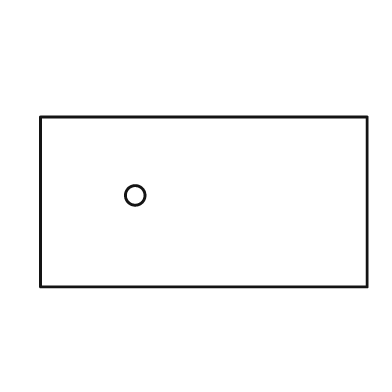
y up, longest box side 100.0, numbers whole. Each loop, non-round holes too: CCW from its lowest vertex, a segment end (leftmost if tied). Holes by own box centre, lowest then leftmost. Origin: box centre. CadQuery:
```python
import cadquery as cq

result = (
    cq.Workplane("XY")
    .moveTo(-50.0, -26.0)
    .lineTo(50.0, -26.0)
    .lineTo(50.0, 26.0)
    .lineTo(-50.0, 26.0)
    .close()
    .moveTo(-21.0, 2.0)
    .circle(3.0)
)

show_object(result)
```